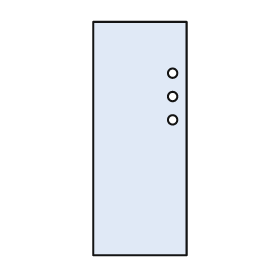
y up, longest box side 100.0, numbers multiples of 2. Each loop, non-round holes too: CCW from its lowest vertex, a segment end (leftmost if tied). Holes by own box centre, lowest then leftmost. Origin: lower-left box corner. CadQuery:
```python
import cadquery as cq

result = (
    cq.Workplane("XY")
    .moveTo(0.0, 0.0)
    .lineTo(40.0, 0.0)
    .lineTo(40.0, 100.0)
    .lineTo(0.0, 100.0)
    .close()
    .moveTo(34.0, 58.0)
    .circle(2.0)
    .moveTo(34.0, 68.0)
    .circle(2.0)
    .moveTo(34.0, 78.0)
    .circle(2.0)
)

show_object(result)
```